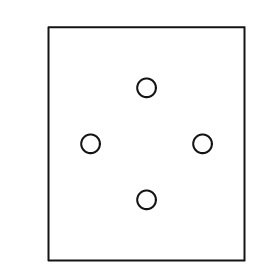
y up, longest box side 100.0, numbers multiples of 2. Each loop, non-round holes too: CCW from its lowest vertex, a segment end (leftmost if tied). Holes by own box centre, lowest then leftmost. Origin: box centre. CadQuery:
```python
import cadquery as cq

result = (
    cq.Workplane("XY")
    .moveTo(-42.0, -50.0)
    .lineTo(42.0, -50.0)
    .lineTo(42.0, 50.0)
    .lineTo(-42.0, 50.0)
    .close()
    .moveTo(0.0, -24.0)
    .circle(4.0)
    .moveTo(-24.0, 0.0)
    .circle(4.0)
    .moveTo(24.0, 0.0)
    .circle(4.0)
    .moveTo(0.0, 24.0)
    .circle(4.0)
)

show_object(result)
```